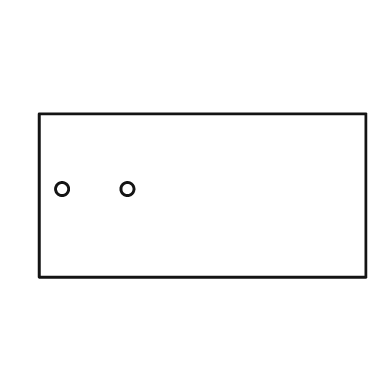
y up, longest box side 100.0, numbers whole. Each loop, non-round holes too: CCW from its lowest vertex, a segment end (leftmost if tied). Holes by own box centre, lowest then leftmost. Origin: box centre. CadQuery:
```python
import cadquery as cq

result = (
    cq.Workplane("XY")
    .moveTo(-50.0, -25.0)
    .lineTo(50.0, -25.0)
    .lineTo(50.0, 25.0)
    .lineTo(-50.0, 25.0)
    .close()
    .moveTo(-43.0, 2.0)
    .circle(2.0)
    .moveTo(-23.0, 2.0)
    .circle(2.0)
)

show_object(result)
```